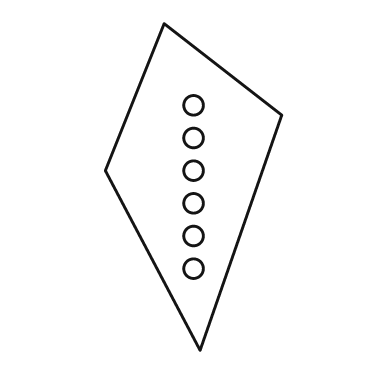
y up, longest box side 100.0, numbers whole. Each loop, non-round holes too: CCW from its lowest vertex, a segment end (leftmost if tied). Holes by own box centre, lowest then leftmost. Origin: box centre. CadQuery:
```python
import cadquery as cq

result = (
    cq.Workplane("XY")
    .moveTo(2.0, -50.0)
    .lineTo(27.0, 22.0)
    .lineTo(-9.0, 50.0)
    .lineTo(-27.0, 5.0)
    .close()
    .moveTo(0.0, -25.0)
    .circle(3.0)
    .moveTo(0.0, -15.0)
    .circle(3.0)
    .moveTo(0.0, -5.0)
    .circle(3.0)
    .moveTo(0.0, 5.0)
    .circle(3.0)
    .moveTo(0.0, 15.0)
    .circle(3.0)
    .moveTo(0.0, 25.0)
    .circle(3.0)
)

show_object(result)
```